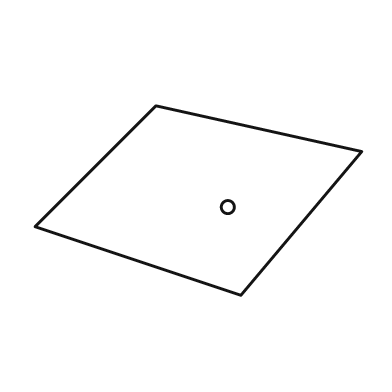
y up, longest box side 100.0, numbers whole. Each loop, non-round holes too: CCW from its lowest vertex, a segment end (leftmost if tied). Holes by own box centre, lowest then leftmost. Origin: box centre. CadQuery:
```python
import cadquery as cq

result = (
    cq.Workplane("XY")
    .moveTo(13.0, -29.0)
    .lineTo(50.0, 15.0)
    .lineTo(-13.0, 29.0)
    .lineTo(-50.0, -8.0)
    .close()
    .moveTo(9.0, -2.0)
    .circle(2.0)
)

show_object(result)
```